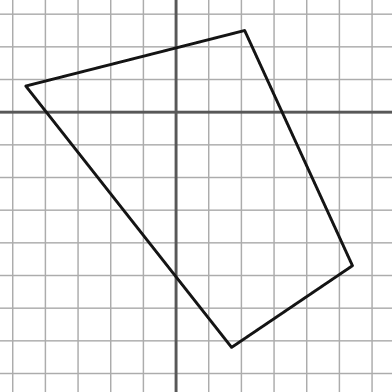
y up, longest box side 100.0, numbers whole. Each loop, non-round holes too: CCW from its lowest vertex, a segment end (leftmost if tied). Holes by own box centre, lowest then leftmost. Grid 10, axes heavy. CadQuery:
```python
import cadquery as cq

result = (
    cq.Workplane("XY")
    .moveTo(17.0, -72.0)
    .lineTo(54.0, -47.0)
    .lineTo(21.0, 25.0)
    .lineTo(-46.0, 8.0)
    .close()
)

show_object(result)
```